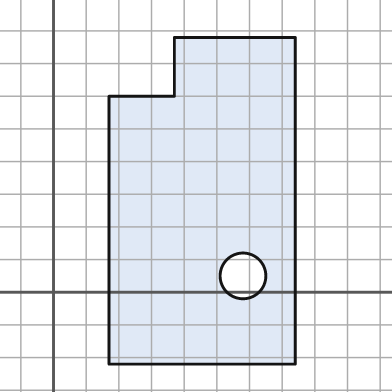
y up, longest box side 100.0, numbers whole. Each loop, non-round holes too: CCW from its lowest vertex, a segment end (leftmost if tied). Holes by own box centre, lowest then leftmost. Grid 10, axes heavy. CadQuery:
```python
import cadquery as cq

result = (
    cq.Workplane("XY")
    .moveTo(17.0, -22.0)
    .lineTo(74.0, -22.0)
    .lineTo(74.0, 78.0)
    .lineTo(37.0, 78.0)
    .lineTo(37.0, 60.0)
    .lineTo(17.0, 60.0)
    .close()
    .moveTo(58.0, 5.0)
    .circle(7.0)
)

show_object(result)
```